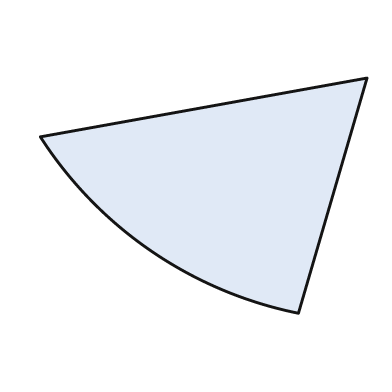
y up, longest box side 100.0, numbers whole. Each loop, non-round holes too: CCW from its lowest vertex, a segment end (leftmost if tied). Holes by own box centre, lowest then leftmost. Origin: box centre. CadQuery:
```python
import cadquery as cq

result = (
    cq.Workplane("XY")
    .moveTo(29.0, -36.0)
    .lineTo(50.0, 36.0)
    .lineTo(-50.0, 18.0)
    .threePointArc((-16.0, -17.0), (29.0, -36.0))
    .close()
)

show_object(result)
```